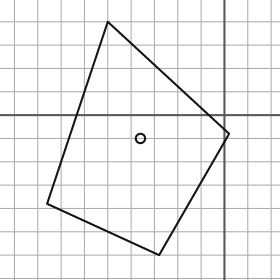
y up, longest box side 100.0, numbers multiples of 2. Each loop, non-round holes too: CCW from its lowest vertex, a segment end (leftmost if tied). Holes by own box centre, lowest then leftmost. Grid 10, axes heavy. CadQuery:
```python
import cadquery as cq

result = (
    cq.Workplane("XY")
    .moveTo(-28.0, -60.0)
    .lineTo(2.0, -8.0)
    .lineTo(-50.0, 40.0)
    .lineTo(-76.0, -38.0)
    .close()
    .moveTo(-36.0, -10.0)
    .circle(2.0)
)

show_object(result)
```